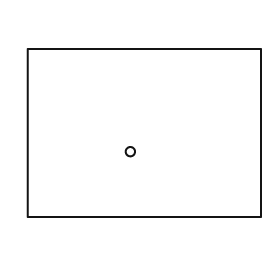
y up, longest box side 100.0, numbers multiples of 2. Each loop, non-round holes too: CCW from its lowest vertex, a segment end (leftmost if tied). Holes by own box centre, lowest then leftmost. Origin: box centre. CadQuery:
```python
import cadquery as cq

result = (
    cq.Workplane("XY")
    .moveTo(-50.0, -36.0)
    .lineTo(50.0, -36.0)
    .lineTo(50.0, 36.0)
    .lineTo(-50.0, 36.0)
    .close()
    .moveTo(-6.0, -8.0)
    .circle(2.0)
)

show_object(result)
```